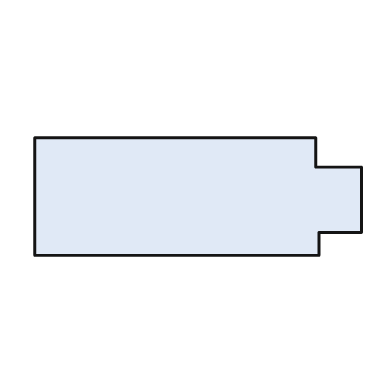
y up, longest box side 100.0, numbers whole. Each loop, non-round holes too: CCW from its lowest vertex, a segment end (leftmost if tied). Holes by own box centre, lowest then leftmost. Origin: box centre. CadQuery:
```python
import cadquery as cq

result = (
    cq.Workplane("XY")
    .moveTo(-50.0, -18.0)
    .lineTo(37.0, -18.0)
    .lineTo(37.0, -11.0)
    .lineTo(50.0, -11.0)
    .lineTo(50.0, 9.0)
    .lineTo(36.0, 9.0)
    .lineTo(36.0, 18.0)
    .lineTo(-50.0, 18.0)
    .close()
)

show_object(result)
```